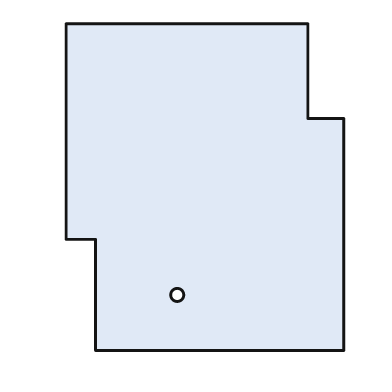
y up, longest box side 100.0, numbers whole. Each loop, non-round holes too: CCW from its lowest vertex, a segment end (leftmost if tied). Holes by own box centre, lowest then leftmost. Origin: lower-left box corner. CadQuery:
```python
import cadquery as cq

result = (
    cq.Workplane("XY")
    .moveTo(9.0, 0.0)
    .lineTo(85.0, 0.0)
    .lineTo(85.0, 71.0)
    .lineTo(74.0, 71.0)
    .lineTo(74.0, 100.0)
    .lineTo(0.0, 100.0)
    .lineTo(0.0, 34.0)
    .lineTo(9.0, 34.0)
    .close()
    .moveTo(34.0, 17.0)
    .circle(2.0)
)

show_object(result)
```